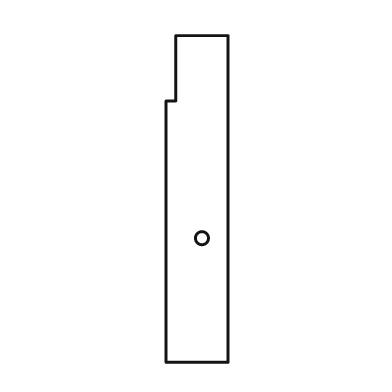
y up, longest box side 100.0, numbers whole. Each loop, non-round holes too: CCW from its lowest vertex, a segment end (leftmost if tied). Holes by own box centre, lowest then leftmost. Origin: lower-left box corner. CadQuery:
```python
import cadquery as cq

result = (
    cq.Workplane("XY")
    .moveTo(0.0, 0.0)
    .lineTo(19.0, 0.0)
    .lineTo(19.0, 100.0)
    .lineTo(3.0, 100.0)
    .lineTo(3.0, 80.0)
    .lineTo(0.0, 80.0)
    .close()
    .moveTo(11.0, 38.0)
    .circle(2.0)
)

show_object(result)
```